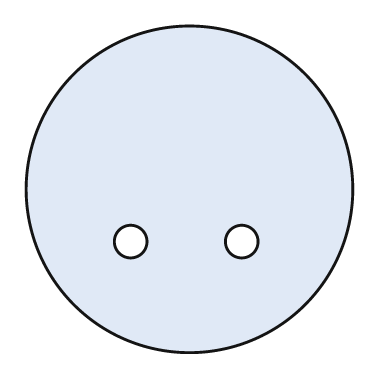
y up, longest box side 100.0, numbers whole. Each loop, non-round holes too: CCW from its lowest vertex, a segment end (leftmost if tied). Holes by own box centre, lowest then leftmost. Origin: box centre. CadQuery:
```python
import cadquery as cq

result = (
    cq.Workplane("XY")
    .moveTo(0.0, 0.0)
    .circle(50.0)
    .moveTo(-18.0, -16.0)
    .circle(5.0)
    .moveTo(16.0, -16.0)
    .circle(5.0)
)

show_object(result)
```